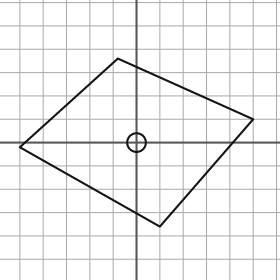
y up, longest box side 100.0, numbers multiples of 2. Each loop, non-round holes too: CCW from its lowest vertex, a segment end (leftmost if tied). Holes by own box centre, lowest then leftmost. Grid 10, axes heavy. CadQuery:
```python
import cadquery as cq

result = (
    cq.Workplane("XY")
    .moveTo(10.0, -36.0)
    .lineTo(50.0, 10.0)
    .lineTo(-8.0, 36.0)
    .lineTo(-50.0, -2.0)
    .close()
    .moveTo(0.0, 0.0)
    .circle(4.0)
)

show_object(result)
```